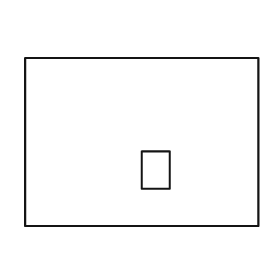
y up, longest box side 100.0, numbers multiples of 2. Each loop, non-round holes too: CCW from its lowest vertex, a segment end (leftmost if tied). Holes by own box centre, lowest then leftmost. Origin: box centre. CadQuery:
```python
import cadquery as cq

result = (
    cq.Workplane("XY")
    .moveTo(-50.0, -36.0)
    .lineTo(50.0, -36.0)
    .lineTo(50.0, 36.0)
    .lineTo(-50.0, 36.0)
    .close()
    .moveTo(0.0, -20.0)
    .lineTo(12.0, -20.0)
    .lineTo(12.0, -4.0)
    .lineTo(0.0, -4.0)
    .close()
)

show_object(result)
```